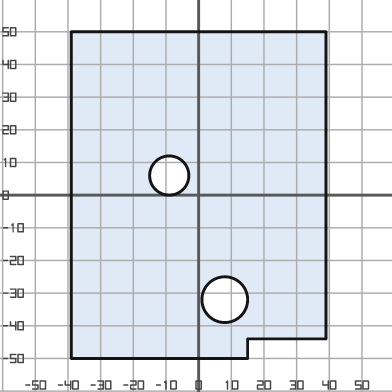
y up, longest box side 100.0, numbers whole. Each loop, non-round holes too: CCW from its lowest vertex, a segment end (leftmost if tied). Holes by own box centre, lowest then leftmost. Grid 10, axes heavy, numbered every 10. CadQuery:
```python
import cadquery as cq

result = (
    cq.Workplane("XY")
    .moveTo(-39.0, -50.0)
    .lineTo(15.0, -50.0)
    .lineTo(15.0, -44.0)
    .lineTo(39.0, -44.0)
    .lineTo(39.0, 50.0)
    .lineTo(-39.0, 50.0)
    .close()
    .moveTo(8.0, -32.0)
    .circle(7.0)
    .moveTo(-9.0, 6.0)
    .circle(6.0)
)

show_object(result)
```